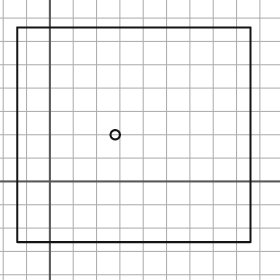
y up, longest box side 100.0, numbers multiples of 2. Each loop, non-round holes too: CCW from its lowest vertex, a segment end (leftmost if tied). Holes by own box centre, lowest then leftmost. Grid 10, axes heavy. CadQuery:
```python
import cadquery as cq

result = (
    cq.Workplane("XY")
    .moveTo(-14.0, -26.0)
    .lineTo(86.0, -26.0)
    .lineTo(86.0, 66.0)
    .lineTo(-14.0, 66.0)
    .close()
    .moveTo(28.0, 20.0)
    .circle(2.0)
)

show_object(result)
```